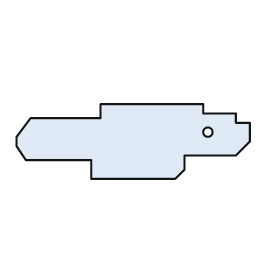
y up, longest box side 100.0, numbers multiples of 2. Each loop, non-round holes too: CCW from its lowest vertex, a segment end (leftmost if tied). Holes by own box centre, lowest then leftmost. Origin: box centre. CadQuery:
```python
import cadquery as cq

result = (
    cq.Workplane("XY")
    .moveTo(-18.0, -16.0)
    .lineTo(18.0, -16.0)
    .lineTo(22.0, -12.0)
    .lineTo(22.0, -6.0)
    .lineTo(44.0, -6.0)
    .lineTo(50.0, 0.0)
    .lineTo(50.0, 8.0)
    .lineTo(44.0, 8.0)
    .lineTo(44.0, 12.0)
    .lineTo(30.0, 12.0)
    .lineTo(30.0, 16.0)
    .lineTo(-14.0, 16.0)
    .lineTo(-14.0, 10.0)
    .lineTo(-44.0, 10.0)
    .lineTo(-50.0, 2.0)
    .lineTo(-50.0, -2.0)
    .lineTo(-46.0, -8.0)
    .lineTo(-18.0, -8.0)
    .close()
    .moveTo(32.0, 4.0)
    .circle(2.0)
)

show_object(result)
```